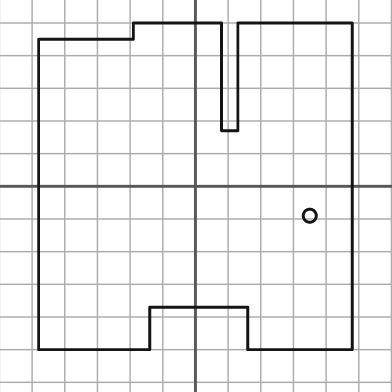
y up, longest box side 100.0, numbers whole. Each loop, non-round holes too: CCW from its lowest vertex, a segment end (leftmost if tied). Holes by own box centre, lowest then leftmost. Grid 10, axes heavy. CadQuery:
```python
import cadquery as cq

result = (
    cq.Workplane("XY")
    .moveTo(-48.0, -50.0)
    .lineTo(-14.0, -50.0)
    .lineTo(-14.0, -37.0)
    .lineTo(16.0, -37.0)
    .lineTo(16.0, -50.0)
    .lineTo(48.0, -50.0)
    .lineTo(48.0, 50.0)
    .lineTo(13.0, 50.0)
    .lineTo(13.0, 17.0)
    .lineTo(8.0, 17.0)
    .lineTo(8.0, 50.0)
    .lineTo(-19.0, 50.0)
    .lineTo(-19.0, 45.0)
    .lineTo(-48.0, 45.0)
    .close()
    .moveTo(35.0, -9.0)
    .circle(2.0)
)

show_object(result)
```